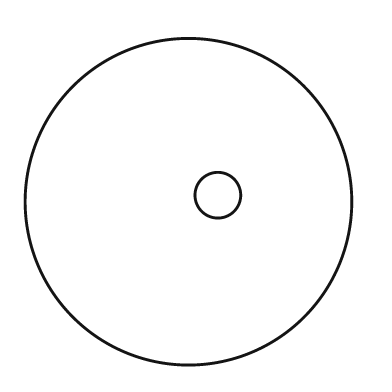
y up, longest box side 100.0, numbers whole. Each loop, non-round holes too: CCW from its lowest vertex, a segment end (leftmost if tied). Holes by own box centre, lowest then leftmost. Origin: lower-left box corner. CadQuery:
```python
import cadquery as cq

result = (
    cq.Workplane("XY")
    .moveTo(50.0, 50.0)
    .circle(50.0)
    .moveTo(59.0, 52.0)
    .circle(7.0)
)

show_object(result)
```